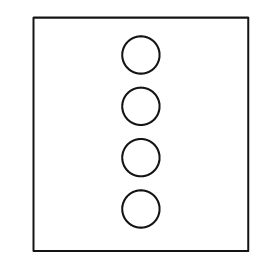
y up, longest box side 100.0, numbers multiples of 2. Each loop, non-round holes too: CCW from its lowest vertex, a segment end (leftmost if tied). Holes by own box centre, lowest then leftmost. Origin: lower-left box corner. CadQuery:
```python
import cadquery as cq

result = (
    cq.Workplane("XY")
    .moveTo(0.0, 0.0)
    .lineTo(92.0, 0.0)
    .lineTo(92.0, 100.0)
    .lineTo(0.0, 100.0)
    .close()
    .moveTo(46.0, 18.0)
    .circle(8.0)
    .moveTo(46.0, 40.0)
    .circle(8.0)
    .moveTo(46.0, 62.0)
    .circle(8.0)
    .moveTo(46.0, 84.0)
    .circle(8.0)
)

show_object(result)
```